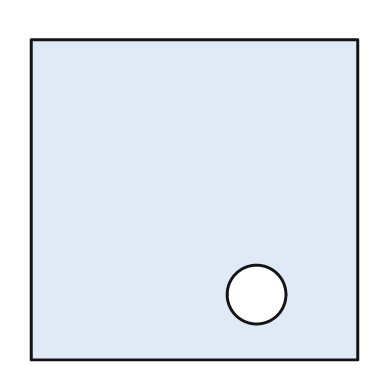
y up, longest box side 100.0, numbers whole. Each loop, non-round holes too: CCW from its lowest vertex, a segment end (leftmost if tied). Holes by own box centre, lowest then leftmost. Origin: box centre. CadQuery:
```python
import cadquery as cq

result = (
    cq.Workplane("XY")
    .moveTo(-50.0, -49.0)
    .lineTo(50.0, -49.0)
    .lineTo(50.0, 49.0)
    .lineTo(-50.0, 49.0)
    .close()
    .moveTo(19.0, -29.0)
    .circle(9.0)
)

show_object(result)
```